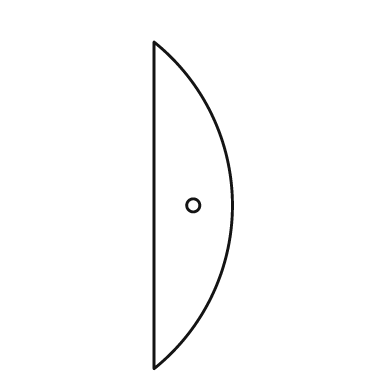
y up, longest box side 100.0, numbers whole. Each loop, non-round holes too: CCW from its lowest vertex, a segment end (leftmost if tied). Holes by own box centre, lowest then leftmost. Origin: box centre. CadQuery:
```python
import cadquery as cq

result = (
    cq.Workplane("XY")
    .moveTo(-12.0, -50.0)
    .threePointArc((12.0, 0.0), (-12.0, 50.0))
    .close()
    .moveTo(0.0, 0.0)
    .circle(2.0)
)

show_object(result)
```